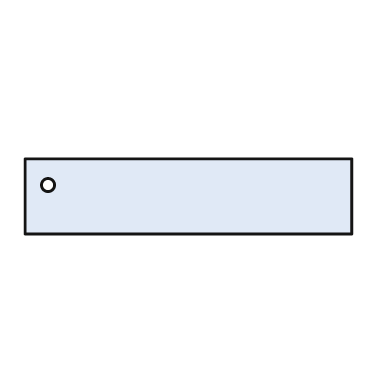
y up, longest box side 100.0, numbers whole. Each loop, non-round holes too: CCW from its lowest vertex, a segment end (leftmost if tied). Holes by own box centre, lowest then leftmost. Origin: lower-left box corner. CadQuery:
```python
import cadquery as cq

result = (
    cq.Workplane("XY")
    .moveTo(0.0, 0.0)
    .lineTo(100.0, 0.0)
    .lineTo(100.0, 23.0)
    .lineTo(0.0, 23.0)
    .close()
    .moveTo(7.0, 15.0)
    .circle(2.0)
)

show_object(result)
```